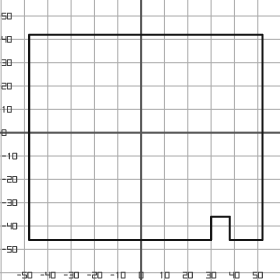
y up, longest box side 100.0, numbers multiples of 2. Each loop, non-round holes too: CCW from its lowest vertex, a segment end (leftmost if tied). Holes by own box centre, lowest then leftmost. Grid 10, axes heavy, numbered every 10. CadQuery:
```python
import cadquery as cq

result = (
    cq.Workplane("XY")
    .moveTo(-48.0, -46.0)
    .lineTo(30.0, -46.0)
    .lineTo(30.0, -36.0)
    .lineTo(38.0, -36.0)
    .lineTo(38.0, -46.0)
    .lineTo(52.0, -46.0)
    .lineTo(52.0, 42.0)
    .lineTo(-48.0, 42.0)
    .close()
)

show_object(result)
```